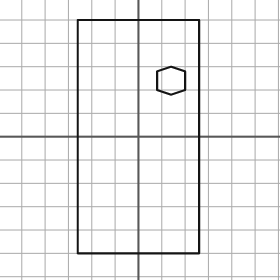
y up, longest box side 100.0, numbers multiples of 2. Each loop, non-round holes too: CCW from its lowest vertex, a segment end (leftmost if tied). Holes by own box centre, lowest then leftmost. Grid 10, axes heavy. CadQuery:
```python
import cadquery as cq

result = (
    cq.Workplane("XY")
    .moveTo(-26.0, -50.0)
    .lineTo(26.0, -50.0)
    .lineTo(26.0, 50.0)
    .lineTo(-26.0, 50.0)
    .close()
    .moveTo(14.0, 18.0)
    .lineTo(20.0, 20.0)
    .lineTo(20.0, 28.0)
    .lineTo(14.0, 30.0)
    .lineTo(8.0, 28.0)
    .lineTo(8.0, 20.0)
    .close()
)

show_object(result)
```